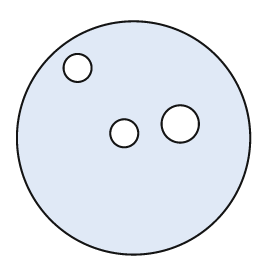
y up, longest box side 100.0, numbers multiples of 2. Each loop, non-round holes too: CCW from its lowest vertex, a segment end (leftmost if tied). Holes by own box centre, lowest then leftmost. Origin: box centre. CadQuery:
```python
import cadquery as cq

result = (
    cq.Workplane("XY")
    .moveTo(0.0, 0.0)
    .circle(50.0)
    .moveTo(-4.0, 2.0)
    .circle(6.0)
    .moveTo(20.0, 6.0)
    .circle(8.0)
    .moveTo(-24.0, 30.0)
    .circle(6.0)
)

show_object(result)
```